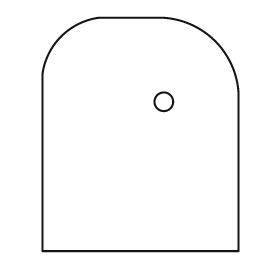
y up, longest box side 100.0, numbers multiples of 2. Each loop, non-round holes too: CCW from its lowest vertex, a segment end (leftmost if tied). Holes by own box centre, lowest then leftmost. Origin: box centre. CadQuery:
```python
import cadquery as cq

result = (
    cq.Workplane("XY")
    .moveTo(-42.0, -50.0)
    .lineTo(42.0, -50.0)
    .lineTo(42.0, 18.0)
    .threePointArc((32.0, 40.0), (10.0, 50.0))
    .lineTo(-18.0, 50.0)
    .threePointArc((-34.0, 42.0), (-42.0, 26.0))
    .close()
    .moveTo(10.0, 14.0)
    .circle(4.0)
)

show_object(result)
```